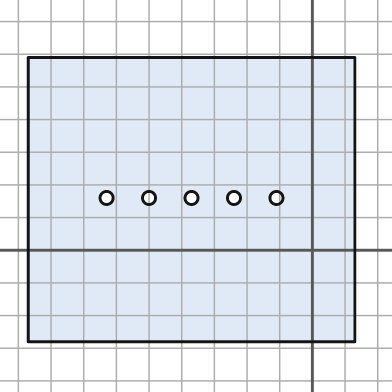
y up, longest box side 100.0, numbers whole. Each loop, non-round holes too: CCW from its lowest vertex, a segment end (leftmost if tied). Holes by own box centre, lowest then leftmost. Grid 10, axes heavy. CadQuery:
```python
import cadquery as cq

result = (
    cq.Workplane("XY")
    .moveTo(-87.0, -28.0)
    .lineTo(13.0, -28.0)
    .lineTo(13.0, 59.0)
    .lineTo(-87.0, 59.0)
    .close()
    .moveTo(-63.0, 16.0)
    .circle(2.0)
    .moveTo(-50.0, 16.0)
    .circle(2.0)
    .moveTo(-37.0, 16.0)
    .circle(2.0)
    .moveTo(-24.0, 16.0)
    .circle(2.0)
    .moveTo(-11.0, 16.0)
    .circle(2.0)
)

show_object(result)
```